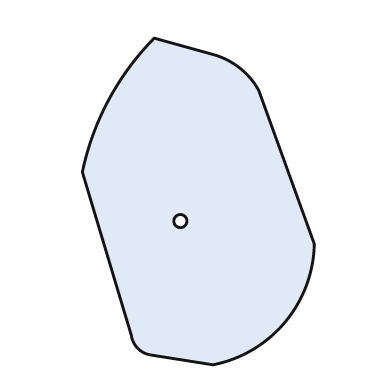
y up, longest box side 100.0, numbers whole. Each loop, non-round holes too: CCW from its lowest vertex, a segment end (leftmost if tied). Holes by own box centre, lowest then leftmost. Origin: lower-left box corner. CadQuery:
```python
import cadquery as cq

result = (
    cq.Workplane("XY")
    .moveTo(40.0, 0.0)
    .threePointArc((62.0, 13.0), (71.0, 37.0))
    .lineTo(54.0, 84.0)
    .threePointArc((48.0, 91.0), (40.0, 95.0))
    .lineTo(22.0, 100.0)
    .threePointArc((8.0, 81.0), (0.0, 59.0))
    .lineTo(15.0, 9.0)
    .threePointArc((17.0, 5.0), (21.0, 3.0))
    .close()
    .moveTo(30.0, 44.0)
    .circle(2.0)
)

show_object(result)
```